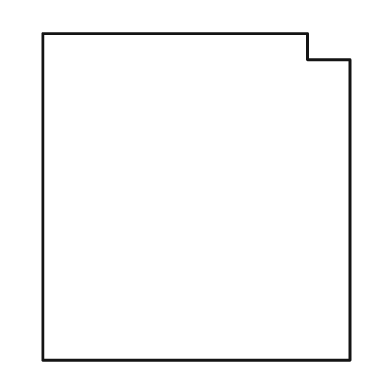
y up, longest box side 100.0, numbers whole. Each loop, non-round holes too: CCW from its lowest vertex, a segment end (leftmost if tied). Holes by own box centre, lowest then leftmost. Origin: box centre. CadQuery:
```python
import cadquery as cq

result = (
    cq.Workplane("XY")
    .moveTo(-47.0, -50.0)
    .lineTo(47.0, -50.0)
    .lineTo(47.0, 42.0)
    .lineTo(34.0, 42.0)
    .lineTo(34.0, 50.0)
    .lineTo(-47.0, 50.0)
    .close()
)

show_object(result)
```